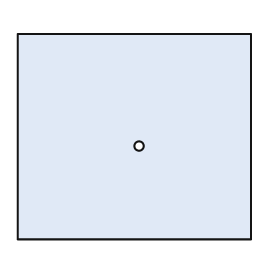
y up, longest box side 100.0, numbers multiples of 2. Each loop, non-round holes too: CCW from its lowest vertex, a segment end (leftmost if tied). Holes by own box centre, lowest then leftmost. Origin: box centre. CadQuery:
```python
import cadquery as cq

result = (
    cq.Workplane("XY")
    .moveTo(-50.0, -44.0)
    .lineTo(50.0, -44.0)
    .lineTo(50.0, 44.0)
    .lineTo(-50.0, 44.0)
    .close()
    .moveTo(2.0, -4.0)
    .circle(2.0)
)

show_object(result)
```